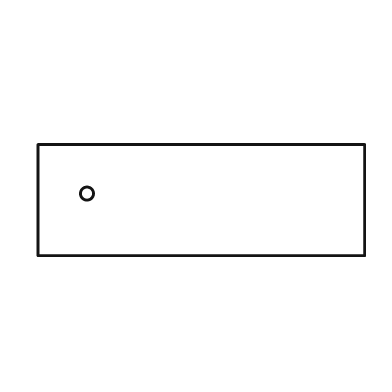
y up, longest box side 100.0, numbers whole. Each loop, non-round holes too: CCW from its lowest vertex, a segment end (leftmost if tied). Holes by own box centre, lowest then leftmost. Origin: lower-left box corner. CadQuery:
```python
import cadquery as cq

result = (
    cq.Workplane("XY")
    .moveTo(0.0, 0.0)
    .lineTo(100.0, 0.0)
    .lineTo(100.0, 34.0)
    .lineTo(0.0, 34.0)
    .close()
    .moveTo(15.0, 19.0)
    .circle(2.0)
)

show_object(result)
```